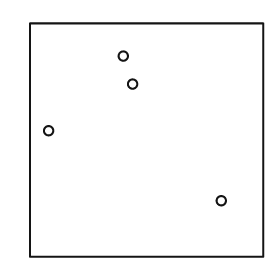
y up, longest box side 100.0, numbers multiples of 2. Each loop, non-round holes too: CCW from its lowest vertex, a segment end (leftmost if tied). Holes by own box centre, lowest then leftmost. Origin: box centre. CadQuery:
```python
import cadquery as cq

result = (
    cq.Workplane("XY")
    .moveTo(-50.0, -50.0)
    .lineTo(50.0, -50.0)
    .lineTo(50.0, 50.0)
    .lineTo(-50.0, 50.0)
    .close()
    .moveTo(32.0, -26.0)
    .circle(2.0)
    .moveTo(-42.0, 4.0)
    .circle(2.0)
    .moveTo(-6.0, 24.0)
    .circle(2.0)
    .moveTo(-10.0, 36.0)
    .circle(2.0)
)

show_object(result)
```